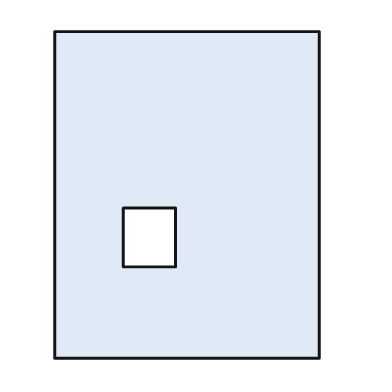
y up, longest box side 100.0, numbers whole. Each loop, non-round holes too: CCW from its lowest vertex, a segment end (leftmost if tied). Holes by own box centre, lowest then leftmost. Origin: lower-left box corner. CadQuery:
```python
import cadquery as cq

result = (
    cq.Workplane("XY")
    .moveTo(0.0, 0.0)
    .lineTo(81.0, 0.0)
    .lineTo(81.0, 100.0)
    .lineTo(0.0, 100.0)
    .close()
    .moveTo(21.0, 28.0)
    .lineTo(37.0, 28.0)
    .lineTo(37.0, 46.0)
    .lineTo(21.0, 46.0)
    .close()
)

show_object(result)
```